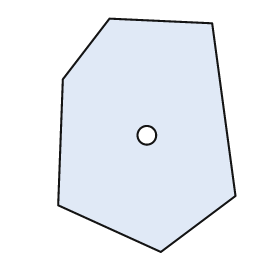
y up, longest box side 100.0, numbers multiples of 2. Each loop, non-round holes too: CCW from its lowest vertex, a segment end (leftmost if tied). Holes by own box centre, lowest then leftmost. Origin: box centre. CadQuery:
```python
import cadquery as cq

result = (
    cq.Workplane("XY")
    .moveTo(6.0, -50.0)
    .lineTo(38.0, -26.0)
    .lineTo(28.0, 48.0)
    .lineTo(-16.0, 50.0)
    .lineTo(-36.0, 24.0)
    .lineTo(-38.0, -30.0)
    .close()
    .moveTo(0.0, 0.0)
    .circle(4.0)
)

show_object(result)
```